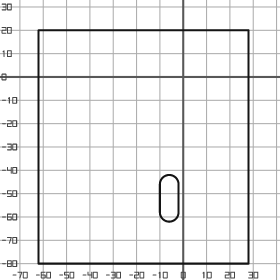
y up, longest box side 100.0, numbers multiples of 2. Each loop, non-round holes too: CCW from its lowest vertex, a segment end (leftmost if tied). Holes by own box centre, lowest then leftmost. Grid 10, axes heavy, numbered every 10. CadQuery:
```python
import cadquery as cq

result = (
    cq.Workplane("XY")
    .moveTo(-62.0, -80.0)
    .lineTo(28.0, -80.0)
    .lineTo(28.0, 20.0)
    .lineTo(-62.0, 20.0)
    .close()
    .moveTo(-10.0, -58.0)
    .threePointArc((-6.0, -62.0), (-2.0, -58.0))
    .lineTo(-2.0, -46.0)
    .threePointArc((-6.0, -42.0), (-10.0, -46.0))
    .close()
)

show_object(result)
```